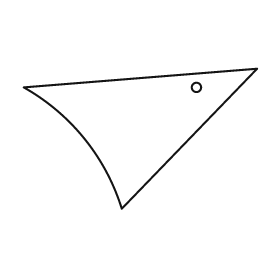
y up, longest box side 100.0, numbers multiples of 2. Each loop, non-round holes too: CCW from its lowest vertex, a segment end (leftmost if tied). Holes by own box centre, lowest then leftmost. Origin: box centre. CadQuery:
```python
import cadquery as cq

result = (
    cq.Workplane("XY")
    .moveTo(-8.0, -30.0)
    .lineTo(50.0, 30.0)
    .lineTo(-50.0, 22.0)
    .threePointArc((-24.0, 0.0), (-8.0, -30.0))
    .close()
    .moveTo(24.0, 22.0)
    .circle(2.0)
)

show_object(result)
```